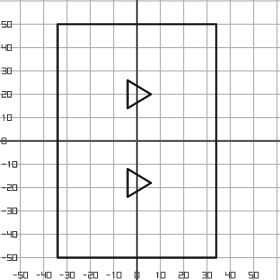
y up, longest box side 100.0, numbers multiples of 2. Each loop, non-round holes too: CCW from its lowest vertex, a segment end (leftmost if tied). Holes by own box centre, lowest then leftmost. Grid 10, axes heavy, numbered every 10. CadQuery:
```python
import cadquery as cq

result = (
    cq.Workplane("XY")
    .moveTo(-34.0, -50.0)
    .lineTo(34.0, -50.0)
    .lineTo(34.0, 50.0)
    .lineTo(-34.0, 50.0)
    .close()
    .moveTo(-4.0, -24.0)
    .lineTo(6.0, -18.0)
    .lineTo(-4.0, -12.0)
    .close()
    .moveTo(-4.0, 14.0)
    .lineTo(6.0, 20.0)
    .lineTo(-4.0, 26.0)
    .close()
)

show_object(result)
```